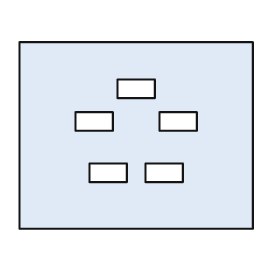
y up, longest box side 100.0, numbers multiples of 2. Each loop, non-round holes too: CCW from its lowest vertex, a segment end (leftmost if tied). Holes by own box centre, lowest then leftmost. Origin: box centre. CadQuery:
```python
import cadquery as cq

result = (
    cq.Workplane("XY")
    .moveTo(-50.0, -40.0)
    .lineTo(50.0, -40.0)
    .lineTo(50.0, 40.0)
    .lineTo(-50.0, 40.0)
    .close()
    .moveTo(-20.0, -20.0)
    .lineTo(-4.0, -20.0)
    .lineTo(-4.0, -12.0)
    .lineTo(-20.0, -12.0)
    .close()
    .moveTo(4.0, -20.0)
    .lineTo(20.0, -20.0)
    .lineTo(20.0, -12.0)
    .lineTo(4.0, -12.0)
    .close()
    .moveTo(-26.0, 2.0)
    .lineTo(-10.0, 2.0)
    .lineTo(-10.0, 10.0)
    .lineTo(-26.0, 10.0)
    .close()
    .moveTo(10.0, 2.0)
    .lineTo(26.0, 2.0)
    .lineTo(26.0, 10.0)
    .lineTo(10.0, 10.0)
    .close()
    .moveTo(-8.0, 16.0)
    .lineTo(8.0, 16.0)
    .lineTo(8.0, 24.0)
    .lineTo(-8.0, 24.0)
    .close()
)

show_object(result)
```